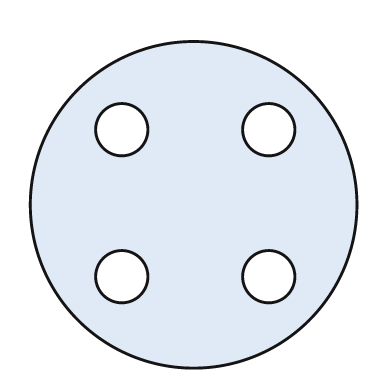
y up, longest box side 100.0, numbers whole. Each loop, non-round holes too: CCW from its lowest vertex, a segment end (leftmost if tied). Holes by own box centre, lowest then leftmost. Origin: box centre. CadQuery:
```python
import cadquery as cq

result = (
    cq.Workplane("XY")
    .moveTo(0.0, 0.0)
    .circle(50.0)
    .moveTo(-22.0, -22.0)
    .circle(8.0)
    .moveTo(23.0, -22.0)
    .circle(8.0)
    .moveTo(-22.0, 23.0)
    .circle(8.0)
    .moveTo(23.0, 23.0)
    .circle(8.0)
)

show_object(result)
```